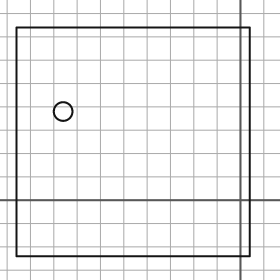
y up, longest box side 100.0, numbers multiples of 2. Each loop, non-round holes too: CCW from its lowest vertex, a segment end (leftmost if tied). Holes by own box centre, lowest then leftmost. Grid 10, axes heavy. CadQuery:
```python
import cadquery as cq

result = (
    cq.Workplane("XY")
    .moveTo(-96.0, -24.0)
    .lineTo(4.0, -24.0)
    .lineTo(4.0, 74.0)
    .lineTo(-96.0, 74.0)
    .close()
    .moveTo(-76.0, 38.0)
    .circle(4.0)
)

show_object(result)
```